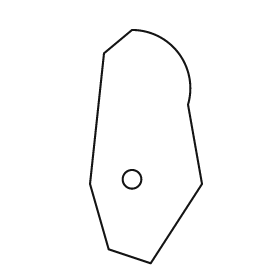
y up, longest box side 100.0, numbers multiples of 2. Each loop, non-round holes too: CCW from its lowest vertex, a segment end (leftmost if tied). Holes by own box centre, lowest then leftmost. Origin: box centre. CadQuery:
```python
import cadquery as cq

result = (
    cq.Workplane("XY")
    .moveTo(2.0, -50.0)
    .lineTo(24.0, -16.0)
    .lineTo(18.0, 18.0)
    .threePointArc((14.0, 40.0), (-6.0, 50.0))
    .lineTo(-18.0, 40.0)
    .lineTo(-24.0, -16.0)
    .lineTo(-16.0, -44.0)
    .close()
    .moveTo(-6.0, -14.0)
    .circle(4.0)
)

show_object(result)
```